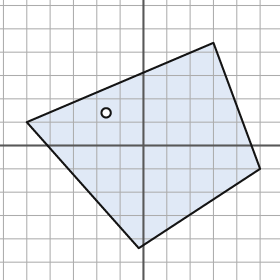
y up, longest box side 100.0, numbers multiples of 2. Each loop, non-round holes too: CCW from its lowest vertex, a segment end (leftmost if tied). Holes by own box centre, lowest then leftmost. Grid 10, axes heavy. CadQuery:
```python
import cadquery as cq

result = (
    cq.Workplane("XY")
    .moveTo(-2.0, -44.0)
    .lineTo(50.0, -10.0)
    .lineTo(30.0, 44.0)
    .lineTo(-50.0, 10.0)
    .close()
    .moveTo(-16.0, 14.0)
    .circle(2.0)
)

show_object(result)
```